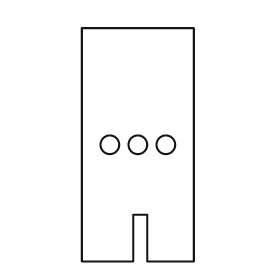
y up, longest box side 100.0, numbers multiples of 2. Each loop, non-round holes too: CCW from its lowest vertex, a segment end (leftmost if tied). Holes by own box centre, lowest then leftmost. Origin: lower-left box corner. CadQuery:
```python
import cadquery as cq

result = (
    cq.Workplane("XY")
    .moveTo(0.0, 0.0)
    .lineTo(22.0, 0.0)
    .lineTo(22.0, 20.0)
    .lineTo(28.0, 20.0)
    .lineTo(28.0, 0.0)
    .lineTo(48.0, 0.0)
    .lineTo(48.0, 100.0)
    .lineTo(0.0, 100.0)
    .close()
    .moveTo(12.0, 50.0)
    .circle(4.0)
    .moveTo(24.0, 50.0)
    .circle(4.0)
    .moveTo(36.0, 50.0)
    .circle(4.0)
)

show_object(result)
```